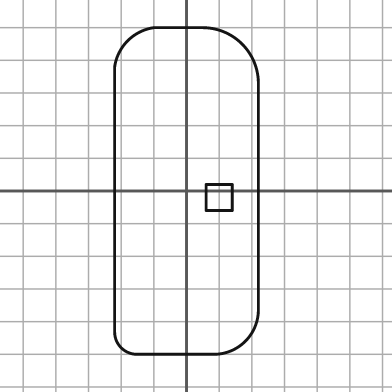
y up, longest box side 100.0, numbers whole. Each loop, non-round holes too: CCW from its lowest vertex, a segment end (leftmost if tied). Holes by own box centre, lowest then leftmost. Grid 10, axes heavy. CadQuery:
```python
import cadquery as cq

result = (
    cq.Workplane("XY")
    .moveTo(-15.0, -50.0)
    .lineTo(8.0, -50.0)
    .threePointArc((18.0, -46.0), (22.0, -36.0))
    .lineTo(22.0, 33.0)
    .threePointArc((17.0, 45.0), (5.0, 50.0))
    .lineTo(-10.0, 50.0)
    .threePointArc((-18.0, 46.0), (-22.0, 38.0))
    .lineTo(-22.0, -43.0)
    .threePointArc((-20.0, -48.0), (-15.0, -50.0))
    .close()
    .moveTo(6.0, -6.0)
    .lineTo(14.0, -6.0)
    .lineTo(14.0, 2.0)
    .lineTo(6.0, 2.0)
    .close()
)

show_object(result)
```